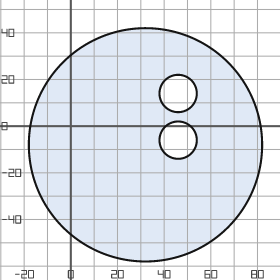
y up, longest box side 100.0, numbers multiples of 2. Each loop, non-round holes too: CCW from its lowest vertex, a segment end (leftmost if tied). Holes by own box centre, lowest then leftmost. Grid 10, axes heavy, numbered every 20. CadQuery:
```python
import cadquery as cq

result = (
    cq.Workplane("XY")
    .moveTo(32.0, -8.0)
    .circle(50.0)
    .moveTo(46.0, -6.0)
    .circle(8.0)
    .moveTo(46.0, 14.0)
    .circle(8.0)
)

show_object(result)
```